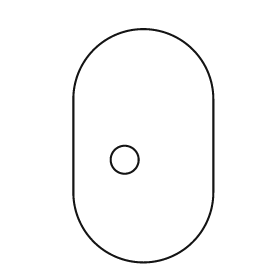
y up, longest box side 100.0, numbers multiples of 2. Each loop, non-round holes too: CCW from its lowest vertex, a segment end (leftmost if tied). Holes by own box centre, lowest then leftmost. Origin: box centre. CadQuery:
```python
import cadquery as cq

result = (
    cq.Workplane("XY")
    .moveTo(-30.0, -20.0)
    .threePointArc((0.0, -50.0), (30.0, -20.0))
    .lineTo(30.0, 20.0)
    .threePointArc((0.0, 50.0), (-30.0, 20.0))
    .close()
    .moveTo(-8.0, -6.0)
    .circle(6.0)
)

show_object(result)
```